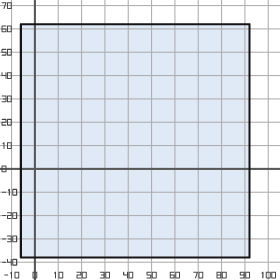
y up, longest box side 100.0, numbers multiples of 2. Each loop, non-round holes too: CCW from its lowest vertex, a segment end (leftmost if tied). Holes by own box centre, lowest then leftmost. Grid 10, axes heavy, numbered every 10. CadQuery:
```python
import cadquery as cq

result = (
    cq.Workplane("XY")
    .moveTo(-6.0, -38.0)
    .lineTo(92.0, -38.0)
    .lineTo(92.0, 62.0)
    .lineTo(-6.0, 62.0)
    .close()
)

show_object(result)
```